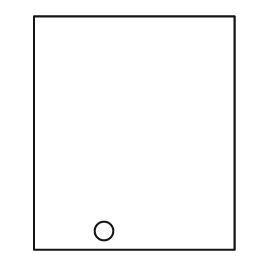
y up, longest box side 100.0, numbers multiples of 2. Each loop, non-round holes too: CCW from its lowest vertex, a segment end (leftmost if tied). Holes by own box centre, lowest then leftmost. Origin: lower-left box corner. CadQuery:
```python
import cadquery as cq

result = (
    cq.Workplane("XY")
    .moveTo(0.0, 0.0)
    .lineTo(86.0, 0.0)
    .lineTo(86.0, 100.0)
    .lineTo(0.0, 100.0)
    .close()
    .moveTo(30.0, 8.0)
    .circle(4.0)
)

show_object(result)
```